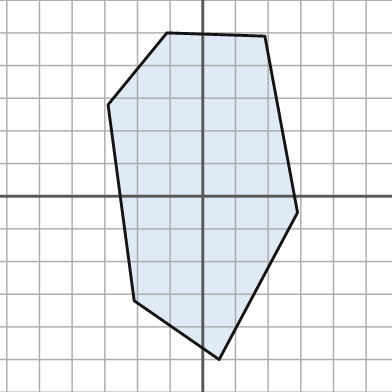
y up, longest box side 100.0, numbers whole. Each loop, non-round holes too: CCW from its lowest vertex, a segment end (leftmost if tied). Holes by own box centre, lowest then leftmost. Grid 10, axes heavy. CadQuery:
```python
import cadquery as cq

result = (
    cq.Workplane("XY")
    .moveTo(5.0, -50.0)
    .lineTo(29.0, -5.0)
    .lineTo(19.0, 49.0)
    .lineTo(-11.0, 50.0)
    .lineTo(-29.0, 28.0)
    .lineTo(-21.0, -32.0)
    .close()
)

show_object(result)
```